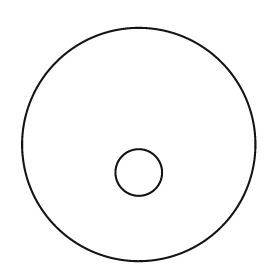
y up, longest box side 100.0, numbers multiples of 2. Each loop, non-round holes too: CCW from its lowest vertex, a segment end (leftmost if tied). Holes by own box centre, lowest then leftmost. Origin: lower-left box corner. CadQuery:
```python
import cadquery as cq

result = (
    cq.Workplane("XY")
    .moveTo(50.0, 50.0)
    .circle(50.0)
    .moveTo(50.0, 38.0)
    .circle(10.0)
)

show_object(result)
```